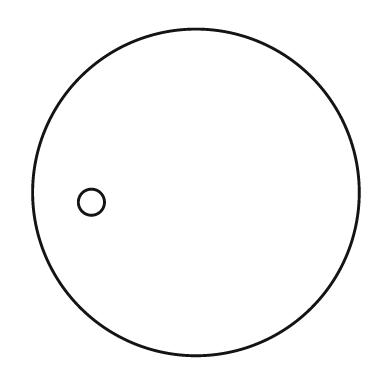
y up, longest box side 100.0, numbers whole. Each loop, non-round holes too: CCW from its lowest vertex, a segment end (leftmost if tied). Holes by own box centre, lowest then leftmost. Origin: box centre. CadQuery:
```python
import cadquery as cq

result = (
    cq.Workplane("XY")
    .moveTo(0.0, 0.0)
    .circle(50.0)
    .moveTo(-32.0, -3.0)
    .circle(4.0)
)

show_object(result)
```